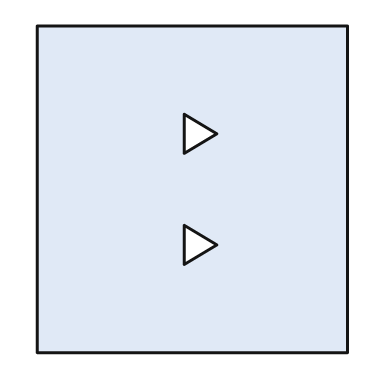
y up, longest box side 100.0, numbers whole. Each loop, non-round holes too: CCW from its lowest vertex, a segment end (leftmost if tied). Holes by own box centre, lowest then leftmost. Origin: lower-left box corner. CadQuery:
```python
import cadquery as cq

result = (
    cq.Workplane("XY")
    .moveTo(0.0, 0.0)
    .lineTo(95.0, 0.0)
    .lineTo(95.0, 100.0)
    .lineTo(0.0, 100.0)
    .close()
    .moveTo(45.0, 27.0)
    .lineTo(55.0, 33.0)
    .lineTo(45.0, 39.0)
    .close()
    .moveTo(45.0, 61.0)
    .lineTo(55.0, 67.0)
    .lineTo(45.0, 73.0)
    .close()
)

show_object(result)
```